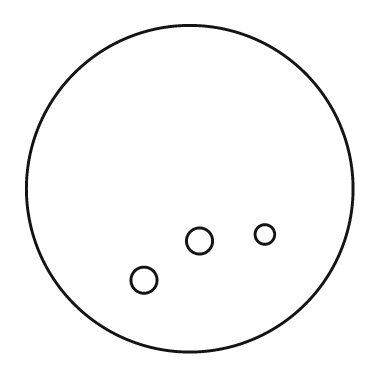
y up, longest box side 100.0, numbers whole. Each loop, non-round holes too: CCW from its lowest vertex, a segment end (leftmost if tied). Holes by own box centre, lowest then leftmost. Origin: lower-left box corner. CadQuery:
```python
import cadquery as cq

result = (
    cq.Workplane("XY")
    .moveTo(50.0, 50.0)
    .circle(50.0)
    .moveTo(36.0, 22.0)
    .circle(4.0)
    .moveTo(53.0, 34.0)
    .circle(4.0)
    .moveTo(73.0, 36.0)
    .circle(3.0)
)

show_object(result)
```